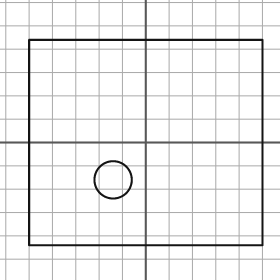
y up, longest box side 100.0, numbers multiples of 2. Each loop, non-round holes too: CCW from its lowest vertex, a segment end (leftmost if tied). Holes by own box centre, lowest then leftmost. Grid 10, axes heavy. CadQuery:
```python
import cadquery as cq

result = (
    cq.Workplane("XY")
    .moveTo(-50.0, -44.0)
    .lineTo(50.0, -44.0)
    .lineTo(50.0, 44.0)
    .lineTo(-50.0, 44.0)
    .close()
    .moveTo(-14.0, -16.0)
    .circle(8.0)
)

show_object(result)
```